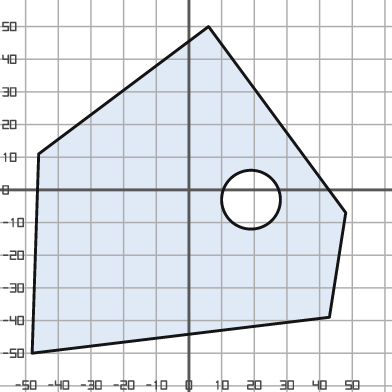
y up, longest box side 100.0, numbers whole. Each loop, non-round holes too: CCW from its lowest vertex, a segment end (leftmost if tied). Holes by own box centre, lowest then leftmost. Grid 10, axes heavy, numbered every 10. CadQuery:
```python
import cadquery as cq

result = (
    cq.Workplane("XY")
    .moveTo(-48.0, -50.0)
    .lineTo(43.0, -39.0)
    .lineTo(48.0, -7.0)
    .lineTo(6.0, 50.0)
    .lineTo(-46.0, 11.0)
    .close()
    .moveTo(19.0, -3.0)
    .circle(9.0)
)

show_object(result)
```